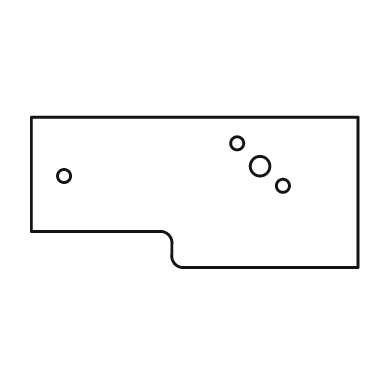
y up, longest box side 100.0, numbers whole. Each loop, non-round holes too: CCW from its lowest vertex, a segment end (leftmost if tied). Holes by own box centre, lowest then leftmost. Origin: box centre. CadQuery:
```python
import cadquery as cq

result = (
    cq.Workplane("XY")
    .moveTo(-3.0, -23.0)
    .lineTo(50.0, -23.0)
    .lineTo(50.0, 23.0)
    .lineTo(-50.0, 23.0)
    .lineTo(-50.0, -12.0)
    .lineTo(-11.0, -12.0)
    .threePointArc((-8.0, -13.0), (-7.0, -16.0))
    .lineTo(-7.0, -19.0)
    .threePointArc((-6.0, -22.0), (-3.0, -23.0))
    .close()
    .moveTo(27.0, 2.0)
    .circle(2.0)
    .moveTo(-40.0, 5.0)
    .circle(2.0)
    .moveTo(20.0, 8.0)
    .circle(3.0)
    .moveTo(13.0, 15.0)
    .circle(2.0)
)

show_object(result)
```